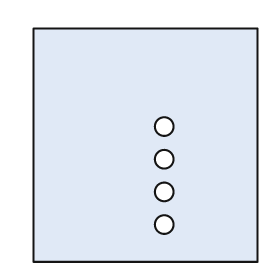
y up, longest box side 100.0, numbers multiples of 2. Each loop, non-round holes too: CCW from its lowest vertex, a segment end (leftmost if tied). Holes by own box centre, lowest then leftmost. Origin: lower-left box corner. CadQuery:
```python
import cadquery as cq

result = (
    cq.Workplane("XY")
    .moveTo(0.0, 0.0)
    .lineTo(96.0, 0.0)
    .lineTo(96.0, 100.0)
    .lineTo(0.0, 100.0)
    .close()
    .moveTo(56.0, 16.0)
    .circle(4.0)
    .moveTo(56.0, 30.0)
    .circle(4.0)
    .moveTo(56.0, 44.0)
    .circle(4.0)
    .moveTo(56.0, 58.0)
    .circle(4.0)
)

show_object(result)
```